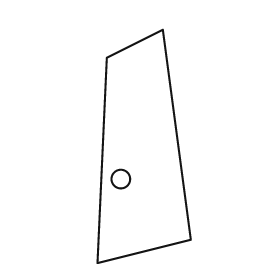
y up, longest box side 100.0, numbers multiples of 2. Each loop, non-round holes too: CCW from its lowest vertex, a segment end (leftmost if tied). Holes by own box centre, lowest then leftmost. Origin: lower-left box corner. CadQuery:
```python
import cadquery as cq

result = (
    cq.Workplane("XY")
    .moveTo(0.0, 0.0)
    .lineTo(40.0, 10.0)
    .lineTo(28.0, 100.0)
    .lineTo(4.0, 88.0)
    .close()
    .moveTo(10.0, 36.0)
    .circle(4.0)
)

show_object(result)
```